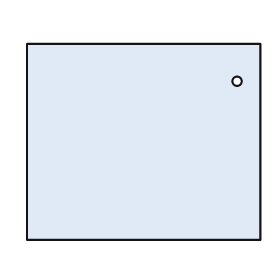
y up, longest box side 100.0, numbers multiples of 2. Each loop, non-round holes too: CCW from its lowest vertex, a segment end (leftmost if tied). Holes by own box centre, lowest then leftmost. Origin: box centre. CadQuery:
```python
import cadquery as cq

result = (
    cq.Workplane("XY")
    .moveTo(-50.0, -42.0)
    .lineTo(50.0, -42.0)
    .lineTo(50.0, 42.0)
    .lineTo(-50.0, 42.0)
    .close()
    .moveTo(40.0, 26.0)
    .circle(2.0)
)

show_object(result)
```